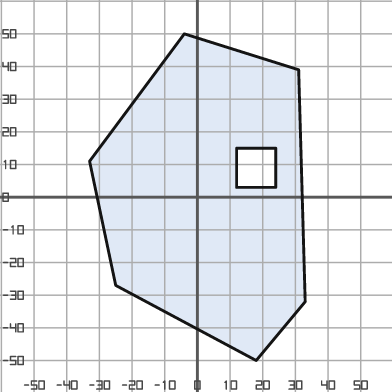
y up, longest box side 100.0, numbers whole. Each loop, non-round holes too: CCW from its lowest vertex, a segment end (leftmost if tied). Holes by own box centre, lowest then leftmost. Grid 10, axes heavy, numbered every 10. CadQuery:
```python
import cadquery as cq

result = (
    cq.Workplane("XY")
    .moveTo(18.0, -50.0)
    .lineTo(33.0, -32.0)
    .lineTo(31.0, 39.0)
    .lineTo(-4.0, 50.0)
    .lineTo(-33.0, 11.0)
    .lineTo(-25.0, -27.0)
    .close()
    .moveTo(12.0, 3.0)
    .lineTo(24.0, 3.0)
    .lineTo(24.0, 15.0)
    .lineTo(12.0, 15.0)
    .close()
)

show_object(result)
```